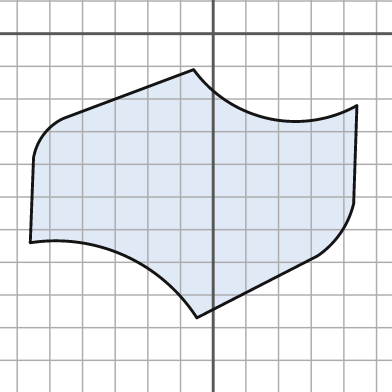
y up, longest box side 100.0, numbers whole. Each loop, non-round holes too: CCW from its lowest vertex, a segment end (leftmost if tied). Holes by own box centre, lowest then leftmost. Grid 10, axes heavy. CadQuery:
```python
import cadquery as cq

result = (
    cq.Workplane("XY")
    .moveTo(-5.0, -87.0)
    .lineTo(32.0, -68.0)
    .threePointArc((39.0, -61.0), (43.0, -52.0))
    .lineTo(44.0, -22.0)
    .threePointArc((17.0, -26.0), (-6.0, -11.0))
    .lineTo(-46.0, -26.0)
    .threePointArc((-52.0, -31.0), (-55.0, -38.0))
    .lineTo(-56.0, -64.0)
    .threePointArc((-27.0, -68.0), (-5.0, -87.0))
    .close()
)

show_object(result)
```